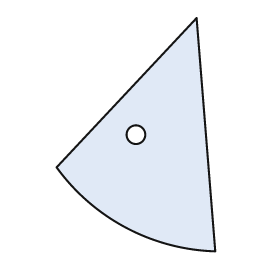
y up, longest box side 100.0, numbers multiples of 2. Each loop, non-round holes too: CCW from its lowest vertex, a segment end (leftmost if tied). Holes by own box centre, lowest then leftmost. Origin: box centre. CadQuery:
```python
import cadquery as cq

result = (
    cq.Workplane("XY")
    .moveTo(34.0, -50.0)
    .lineTo(26.0, 50.0)
    .lineTo(-34.0, -14.0)
    .threePointArc((-4.0, -40.0), (34.0, -50.0))
    .close()
    .moveTo(0.0, 0.0)
    .circle(4.0)
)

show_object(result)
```